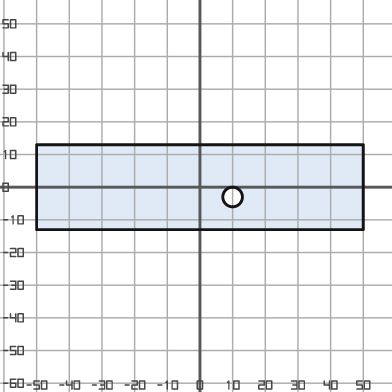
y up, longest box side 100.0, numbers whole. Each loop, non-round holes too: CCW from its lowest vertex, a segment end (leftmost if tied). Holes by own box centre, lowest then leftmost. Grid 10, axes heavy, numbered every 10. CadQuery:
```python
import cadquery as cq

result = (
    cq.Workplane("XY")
    .moveTo(-50.0, -13.0)
    .lineTo(50.0, -13.0)
    .lineTo(50.0, 13.0)
    .lineTo(-50.0, 13.0)
    .close()
    .moveTo(10.0, -3.0)
    .circle(3.0)
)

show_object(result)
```